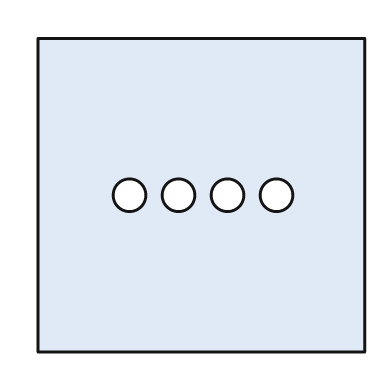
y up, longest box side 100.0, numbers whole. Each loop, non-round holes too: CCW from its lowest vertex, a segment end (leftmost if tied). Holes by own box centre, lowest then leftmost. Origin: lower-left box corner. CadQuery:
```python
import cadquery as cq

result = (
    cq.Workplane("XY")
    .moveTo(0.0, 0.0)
    .lineTo(100.0, 0.0)
    .lineTo(100.0, 96.0)
    .lineTo(0.0, 96.0)
    .close()
    .moveTo(28.0, 48.0)
    .circle(5.0)
    .moveTo(43.0, 48.0)
    .circle(5.0)
    .moveTo(58.0, 48.0)
    .circle(5.0)
    .moveTo(73.0, 48.0)
    .circle(5.0)
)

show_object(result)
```